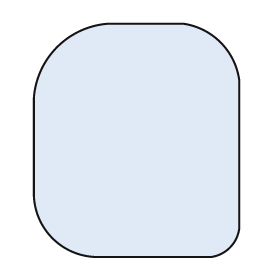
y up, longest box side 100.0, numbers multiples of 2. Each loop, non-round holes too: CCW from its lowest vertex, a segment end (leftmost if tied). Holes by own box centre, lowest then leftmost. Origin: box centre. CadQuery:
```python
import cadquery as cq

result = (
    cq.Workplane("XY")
    .moveTo(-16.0, -50.0)
    .lineTo(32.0, -50.0)
    .threePointArc((40.0, -46.0), (44.0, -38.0))
    .lineTo(44.0, 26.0)
    .threePointArc((36.0, 42.0), (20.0, 50.0))
    .lineTo(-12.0, 50.0)
    .threePointArc((-34.0, 40.0), (-44.0, 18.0))
    .lineTo(-44.0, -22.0)
    .threePointArc((-36.0, -42.0), (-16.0, -50.0))
    .close()
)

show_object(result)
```